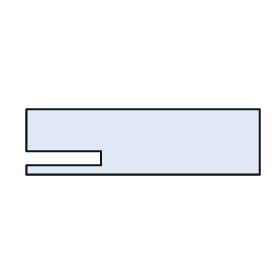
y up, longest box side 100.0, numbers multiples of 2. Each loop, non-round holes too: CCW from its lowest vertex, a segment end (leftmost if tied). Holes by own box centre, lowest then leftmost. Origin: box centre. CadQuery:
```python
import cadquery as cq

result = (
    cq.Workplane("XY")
    .moveTo(-50.0, -14.0)
    .lineTo(50.0, -14.0)
    .lineTo(50.0, 14.0)
    .lineTo(-50.0, 14.0)
    .lineTo(-50.0, -4.0)
    .lineTo(-18.0, -4.0)
    .lineTo(-18.0, -10.0)
    .lineTo(-50.0, -10.0)
    .close()
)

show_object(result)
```